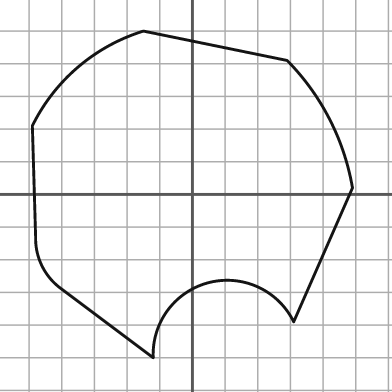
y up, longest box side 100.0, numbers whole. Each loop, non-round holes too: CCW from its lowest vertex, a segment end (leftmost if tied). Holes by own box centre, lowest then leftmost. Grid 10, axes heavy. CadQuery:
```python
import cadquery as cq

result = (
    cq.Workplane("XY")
    .moveTo(-12.0, -50.0)
    .threePointArc((5.0, -27.0), (31.0, -39.0))
    .lineTo(49.0, 2.0)
    .threePointArc((42.0, 23.0), (29.0, 41.0))
    .lineTo(-15.0, 50.0)
    .threePointArc((-35.0, 39.0), (-49.0, 21.0))
    .lineTo(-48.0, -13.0)
    .threePointArc((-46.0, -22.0), (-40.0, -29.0))
    .close()
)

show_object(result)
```